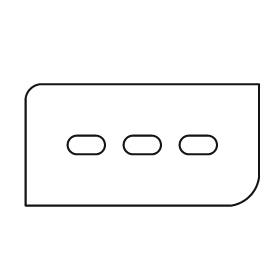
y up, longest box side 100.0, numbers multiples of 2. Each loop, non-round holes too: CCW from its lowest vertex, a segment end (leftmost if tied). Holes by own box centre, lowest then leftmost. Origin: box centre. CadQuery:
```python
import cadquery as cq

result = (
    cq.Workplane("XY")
    .moveTo(-50.0, -26.0)
    .lineTo(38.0, -26.0)
    .threePointArc((46.0, -22.0), (50.0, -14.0))
    .lineTo(50.0, 26.0)
    .lineTo(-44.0, 26.0)
    .threePointArc((-48.0, 24.0), (-50.0, 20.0))
    .close()
    .moveTo(-28.0, -4.0)
    .lineTo(-20.0, -4.0)
    .threePointArc((-16.0, 0.0), (-20.0, 4.0))
    .lineTo(-28.0, 4.0)
    .threePointArc((-32.0, 0.0), (-28.0, -4.0))
    .close()
    .moveTo(-4.0, -4.0)
    .lineTo(4.0, -4.0)
    .threePointArc((8.0, 0.0), (4.0, 4.0))
    .lineTo(-4.0, 4.0)
    .threePointArc((-8.0, 0.0), (-4.0, -4.0))
    .close()
    .moveTo(20.0, -4.0)
    .lineTo(28.0, -4.0)
    .threePointArc((32.0, 0.0), (28.0, 4.0))
    .lineTo(20.0, 4.0)
    .threePointArc((16.0, 0.0), (20.0, -4.0))
    .close()
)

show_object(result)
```